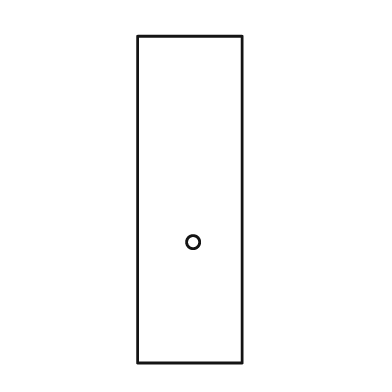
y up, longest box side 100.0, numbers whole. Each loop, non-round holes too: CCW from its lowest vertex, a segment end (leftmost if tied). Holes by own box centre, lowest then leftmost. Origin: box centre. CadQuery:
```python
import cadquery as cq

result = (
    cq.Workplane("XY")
    .moveTo(-16.0, -50.0)
    .lineTo(16.0, -50.0)
    .lineTo(16.0, 50.0)
    .lineTo(-16.0, 50.0)
    .close()
    .moveTo(1.0, -13.0)
    .circle(2.0)
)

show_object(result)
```